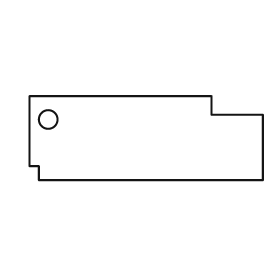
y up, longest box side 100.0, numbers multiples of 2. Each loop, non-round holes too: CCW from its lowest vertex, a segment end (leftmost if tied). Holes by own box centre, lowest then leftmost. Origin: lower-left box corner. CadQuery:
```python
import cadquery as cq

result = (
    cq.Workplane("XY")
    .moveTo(4.0, 0.0)
    .lineTo(100.0, 0.0)
    .lineTo(100.0, 28.0)
    .lineTo(78.0, 28.0)
    .lineTo(78.0, 36.0)
    .lineTo(0.0, 36.0)
    .lineTo(0.0, 6.0)
    .lineTo(4.0, 6.0)
    .close()
    .moveTo(8.0, 26.0)
    .circle(4.0)
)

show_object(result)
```